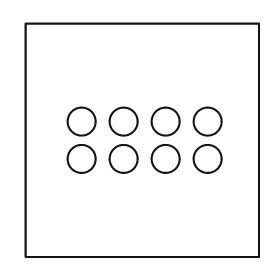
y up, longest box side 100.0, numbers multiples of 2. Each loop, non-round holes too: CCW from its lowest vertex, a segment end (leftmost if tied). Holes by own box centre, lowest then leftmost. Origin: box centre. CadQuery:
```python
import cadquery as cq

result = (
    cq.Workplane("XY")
    .moveTo(-50.0, -50.0)
    .lineTo(50.0, -50.0)
    .lineTo(50.0, 50.0)
    .lineTo(-50.0, 50.0)
    .close()
    .moveTo(-26.0, -8.0)
    .circle(6.0)
    .moveTo(-8.0, -8.0)
    .circle(6.0)
    .moveTo(10.0, -8.0)
    .circle(6.0)
    .moveTo(28.0, -8.0)
    .circle(6.0)
    .moveTo(-26.0, 8.0)
    .circle(6.0)
    .moveTo(-8.0, 8.0)
    .circle(6.0)
    .moveTo(10.0, 8.0)
    .circle(6.0)
    .moveTo(28.0, 8.0)
    .circle(6.0)
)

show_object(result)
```